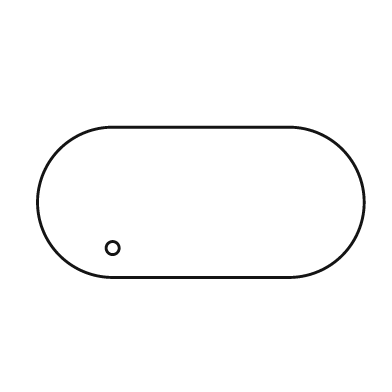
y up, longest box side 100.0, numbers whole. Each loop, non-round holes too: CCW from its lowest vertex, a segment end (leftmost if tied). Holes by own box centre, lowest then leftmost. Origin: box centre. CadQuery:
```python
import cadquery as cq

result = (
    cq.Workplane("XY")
    .moveTo(-27.0, -23.0)
    .lineTo(27.0, -23.0)
    .threePointArc((50.0, 0.0), (27.0, 23.0))
    .lineTo(-27.0, 23.0)
    .threePointArc((-50.0, 0.0), (-27.0, -23.0))
    .close()
    .moveTo(-27.0, -14.0)
    .circle(2.0)
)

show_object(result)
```